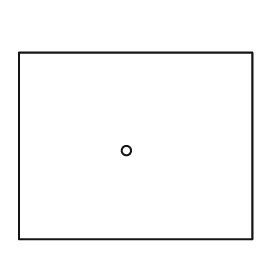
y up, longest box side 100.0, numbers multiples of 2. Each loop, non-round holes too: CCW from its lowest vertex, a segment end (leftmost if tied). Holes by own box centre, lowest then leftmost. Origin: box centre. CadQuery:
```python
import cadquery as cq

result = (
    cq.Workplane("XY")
    .moveTo(-50.0, -40.0)
    .lineTo(50.0, -40.0)
    .lineTo(50.0, 40.0)
    .lineTo(-50.0, 40.0)
    .close()
    .moveTo(-4.0, -2.0)
    .circle(2.0)
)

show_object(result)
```